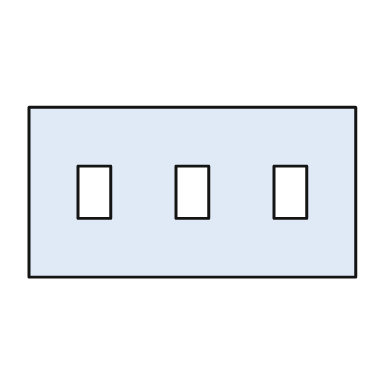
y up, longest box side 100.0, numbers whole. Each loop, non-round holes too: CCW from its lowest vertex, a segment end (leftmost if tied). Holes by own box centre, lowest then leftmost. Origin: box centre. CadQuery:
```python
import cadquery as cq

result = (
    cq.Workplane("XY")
    .moveTo(-50.0, -26.0)
    .lineTo(50.0, -26.0)
    .lineTo(50.0, 26.0)
    .lineTo(-50.0, 26.0)
    .close()
    .moveTo(-35.0, -8.0)
    .lineTo(-25.0, -8.0)
    .lineTo(-25.0, 8.0)
    .lineTo(-35.0, 8.0)
    .close()
    .moveTo(-5.0, -8.0)
    .lineTo(5.0, -8.0)
    .lineTo(5.0, 8.0)
    .lineTo(-5.0, 8.0)
    .close()
    .moveTo(25.0, -8.0)
    .lineTo(35.0, -8.0)
    .lineTo(35.0, 8.0)
    .lineTo(25.0, 8.0)
    .close()
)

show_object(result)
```